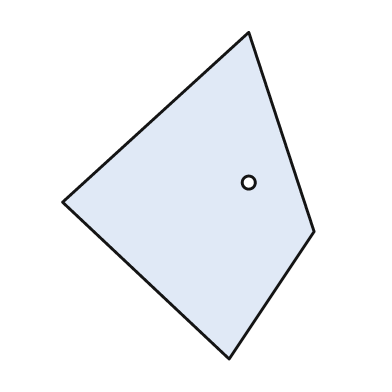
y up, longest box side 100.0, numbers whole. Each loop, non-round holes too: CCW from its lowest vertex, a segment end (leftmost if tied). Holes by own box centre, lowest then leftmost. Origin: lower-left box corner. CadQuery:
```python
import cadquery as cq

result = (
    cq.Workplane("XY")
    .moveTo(51.0, 0.0)
    .lineTo(77.0, 39.0)
    .lineTo(57.0, 100.0)
    .lineTo(0.0, 48.0)
    .close()
    .moveTo(57.0, 54.0)
    .circle(2.0)
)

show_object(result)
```